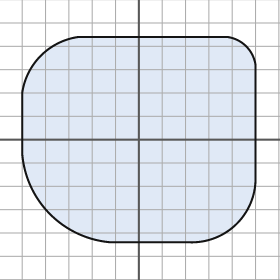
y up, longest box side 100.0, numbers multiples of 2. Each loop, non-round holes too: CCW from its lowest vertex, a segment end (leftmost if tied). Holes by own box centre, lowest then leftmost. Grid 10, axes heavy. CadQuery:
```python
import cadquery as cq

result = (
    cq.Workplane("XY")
    .moveTo(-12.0, -44.0)
    .lineTo(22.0, -44.0)
    .threePointArc((42.0, -36.0), (50.0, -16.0))
    .lineTo(50.0, 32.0)
    .threePointArc((46.0, 40.0), (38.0, 44.0))
    .lineTo(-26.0, 44.0)
    .threePointArc((-42.0, 36.0), (-50.0, 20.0))
    .lineTo(-50.0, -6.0)
    .threePointArc((-38.0, -32.0), (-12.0, -44.0))
    .close()
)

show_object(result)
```